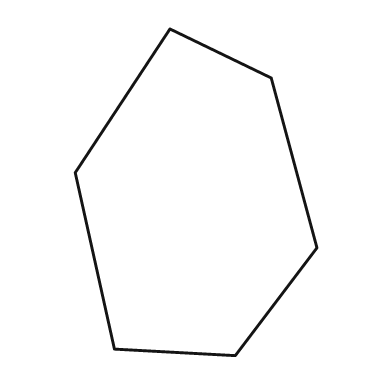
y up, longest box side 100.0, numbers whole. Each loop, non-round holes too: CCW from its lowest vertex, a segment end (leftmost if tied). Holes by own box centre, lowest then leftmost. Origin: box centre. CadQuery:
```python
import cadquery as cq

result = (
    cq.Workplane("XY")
    .moveTo(12.0, -50.0)
    .lineTo(37.0, -17.0)
    .lineTo(23.0, 35.0)
    .lineTo(-8.0, 50.0)
    .lineTo(-37.0, 6.0)
    .lineTo(-25.0, -48.0)
    .close()
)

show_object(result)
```